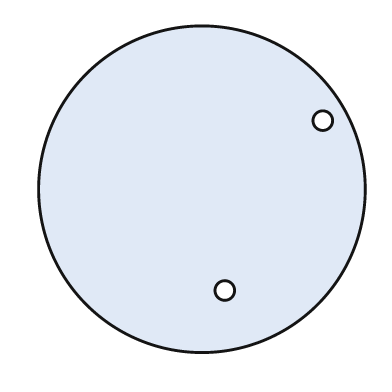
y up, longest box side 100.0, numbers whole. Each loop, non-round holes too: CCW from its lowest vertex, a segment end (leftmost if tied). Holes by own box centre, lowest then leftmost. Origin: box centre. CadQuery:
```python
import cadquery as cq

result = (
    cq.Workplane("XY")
    .moveTo(0.0, 0.0)
    .circle(50.0)
    .moveTo(7.0, -31.0)
    .circle(3.0)
    .moveTo(37.0, 21.0)
    .circle(3.0)
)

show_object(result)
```